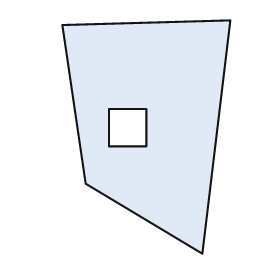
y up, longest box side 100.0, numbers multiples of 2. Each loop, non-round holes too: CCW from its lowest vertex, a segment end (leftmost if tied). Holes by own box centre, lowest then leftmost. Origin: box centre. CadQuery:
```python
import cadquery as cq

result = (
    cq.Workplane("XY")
    .moveTo(24.0, -50.0)
    .lineTo(36.0, 50.0)
    .lineTo(-36.0, 48.0)
    .lineTo(-26.0, -20.0)
    .close()
    .moveTo(-16.0, -4.0)
    .lineTo(0.0, -4.0)
    .lineTo(0.0, 12.0)
    .lineTo(-16.0, 12.0)
    .close()
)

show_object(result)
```